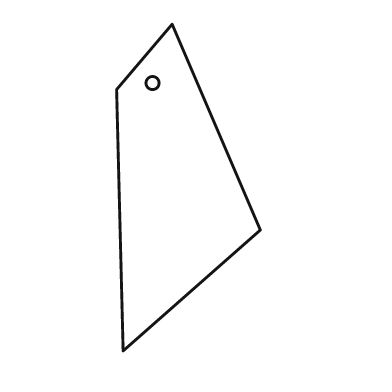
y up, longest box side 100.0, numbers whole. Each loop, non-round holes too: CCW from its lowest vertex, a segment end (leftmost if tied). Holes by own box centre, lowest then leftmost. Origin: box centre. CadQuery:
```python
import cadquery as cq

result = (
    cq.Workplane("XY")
    .moveTo(-20.0, -50.0)
    .lineTo(22.0, -13.0)
    .lineTo(-5.0, 50.0)
    .lineTo(-22.0, 30.0)
    .close()
    .moveTo(-11.0, 32.0)
    .circle(2.0)
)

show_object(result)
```